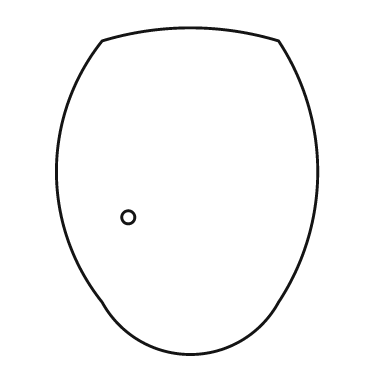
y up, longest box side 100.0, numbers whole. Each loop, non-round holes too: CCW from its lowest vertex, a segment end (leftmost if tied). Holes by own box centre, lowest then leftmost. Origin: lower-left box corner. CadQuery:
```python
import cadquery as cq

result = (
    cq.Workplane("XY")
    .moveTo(14.0, 16.0)
    .threePointArc((41.0, 0.0), (68.0, 16.0))
    .threePointArc((80.0, 56.0), (68.0, 96.0))
    .threePointArc((41.0, 100.0), (14.0, 96.0))
    .threePointArc((0.0, 56.0), (14.0, 16.0))
    .close()
    .moveTo(22.0, 42.0)
    .circle(2.0)
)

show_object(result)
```